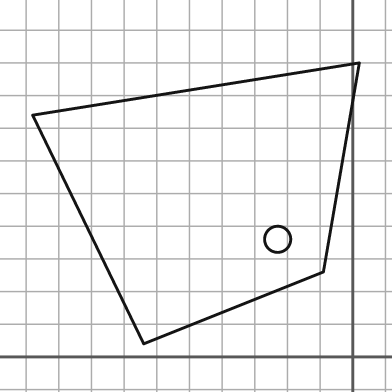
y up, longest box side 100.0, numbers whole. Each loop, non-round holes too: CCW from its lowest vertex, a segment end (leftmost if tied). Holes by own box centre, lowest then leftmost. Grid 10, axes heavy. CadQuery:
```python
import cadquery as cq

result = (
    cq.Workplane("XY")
    .moveTo(-64.0, 4.0)
    .lineTo(-9.0, 26.0)
    .lineTo(2.0, 90.0)
    .lineTo(-98.0, 74.0)
    .close()
    .moveTo(-23.0, 36.0)
    .circle(4.0)
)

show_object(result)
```